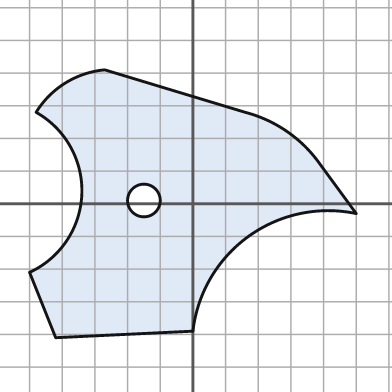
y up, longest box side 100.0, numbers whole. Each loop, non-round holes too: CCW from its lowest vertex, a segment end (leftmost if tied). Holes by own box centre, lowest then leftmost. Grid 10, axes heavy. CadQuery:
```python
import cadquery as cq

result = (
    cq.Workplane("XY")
    .moveTo(-42.0, -41.0)
    .lineTo(0.0, -39.0)
    .threePointArc((17.0, -10.0), (50.0, -3.0))
    .lineTo(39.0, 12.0)
    .threePointArc((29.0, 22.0), (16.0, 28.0))
    .lineTo(-27.0, 41.0)
    .threePointArc((-39.0, 37.0), (-48.0, 28.0))
    .threePointArc((-34.0, 3.0), (-50.0, -21.0))
    .close()
    .moveTo(-15.0, 1.0)
    .circle(5.0)
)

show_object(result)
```